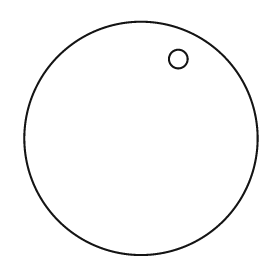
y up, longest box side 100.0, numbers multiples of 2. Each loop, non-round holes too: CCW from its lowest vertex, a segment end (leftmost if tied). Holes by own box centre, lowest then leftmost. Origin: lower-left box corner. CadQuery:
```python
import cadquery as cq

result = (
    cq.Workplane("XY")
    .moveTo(50.0, 50.0)
    .circle(50.0)
    .moveTo(66.0, 84.0)
    .circle(4.0)
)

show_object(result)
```